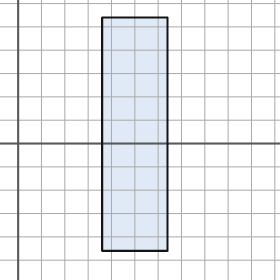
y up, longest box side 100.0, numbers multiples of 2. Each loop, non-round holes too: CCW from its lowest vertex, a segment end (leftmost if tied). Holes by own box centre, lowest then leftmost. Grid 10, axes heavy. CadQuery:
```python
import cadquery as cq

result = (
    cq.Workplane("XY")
    .moveTo(36.0, -46.0)
    .lineTo(64.0, -46.0)
    .lineTo(64.0, 54.0)
    .lineTo(36.0, 54.0)
    .close()
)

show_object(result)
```